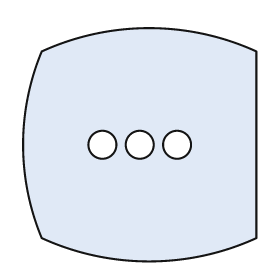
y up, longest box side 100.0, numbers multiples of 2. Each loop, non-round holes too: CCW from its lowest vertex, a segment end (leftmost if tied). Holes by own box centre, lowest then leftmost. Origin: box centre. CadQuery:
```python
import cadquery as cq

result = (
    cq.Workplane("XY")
    .moveTo(-42.0, -40.0)
    .threePointArc((4.0, -50.0), (50.0, -40.0))
    .lineTo(50.0, 40.0)
    .threePointArc((4.0, 50.0), (-42.0, 40.0))
    .threePointArc((-50.0, 0.0), (-42.0, -40.0))
    .close()
    .moveTo(-16.0, 0.0)
    .circle(6.0)
    .moveTo(0.0, 0.0)
    .circle(6.0)
    .moveTo(16.0, 0.0)
    .circle(6.0)
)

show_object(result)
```